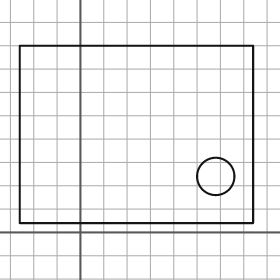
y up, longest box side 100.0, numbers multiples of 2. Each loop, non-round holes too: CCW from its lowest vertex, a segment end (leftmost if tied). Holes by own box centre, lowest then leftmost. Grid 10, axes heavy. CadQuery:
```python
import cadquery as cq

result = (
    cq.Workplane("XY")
    .moveTo(-26.0, 4.0)
    .lineTo(74.0, 4.0)
    .lineTo(74.0, 80.0)
    .lineTo(-26.0, 80.0)
    .close()
    .moveTo(58.0, 24.0)
    .circle(8.0)
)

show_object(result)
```